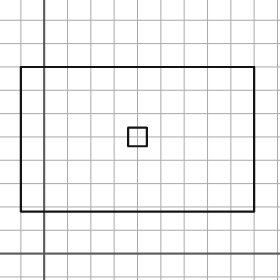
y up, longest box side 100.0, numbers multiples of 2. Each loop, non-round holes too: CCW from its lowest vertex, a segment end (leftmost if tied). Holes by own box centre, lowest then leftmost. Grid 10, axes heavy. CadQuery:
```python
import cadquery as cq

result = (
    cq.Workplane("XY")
    .moveTo(-10.0, 18.0)
    .lineTo(90.0, 18.0)
    .lineTo(90.0, 80.0)
    .lineTo(-10.0, 80.0)
    .close()
    .moveTo(36.0, 46.0)
    .lineTo(44.0, 46.0)
    .lineTo(44.0, 54.0)
    .lineTo(36.0, 54.0)
    .close()
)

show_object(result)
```